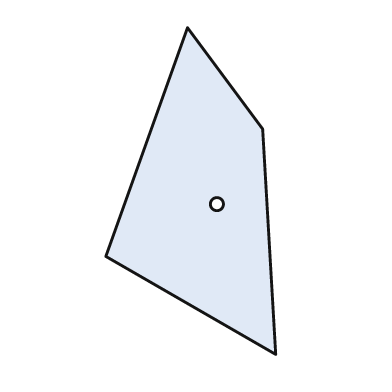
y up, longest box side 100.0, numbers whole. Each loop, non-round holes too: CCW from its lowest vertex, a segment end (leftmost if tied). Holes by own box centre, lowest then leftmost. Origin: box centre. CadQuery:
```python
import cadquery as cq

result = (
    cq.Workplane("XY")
    .moveTo(26.0, -50.0)
    .lineTo(22.0, 19.0)
    .lineTo(-1.0, 50.0)
    .lineTo(-26.0, -20.0)
    .close()
    .moveTo(8.0, -4.0)
    .circle(2.0)
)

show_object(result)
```